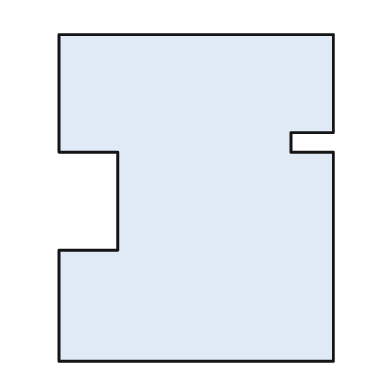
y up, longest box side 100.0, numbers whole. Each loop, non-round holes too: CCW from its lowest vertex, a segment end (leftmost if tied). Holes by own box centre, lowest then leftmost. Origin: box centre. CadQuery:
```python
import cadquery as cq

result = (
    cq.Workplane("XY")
    .moveTo(-42.0, -50.0)
    .lineTo(42.0, -50.0)
    .lineTo(42.0, 14.0)
    .lineTo(29.0, 14.0)
    .lineTo(29.0, 20.0)
    .lineTo(42.0, 20.0)
    .lineTo(42.0, 50.0)
    .lineTo(-42.0, 50.0)
    .lineTo(-42.0, 14.0)
    .lineTo(-24.0, 14.0)
    .lineTo(-24.0, -16.0)
    .lineTo(-42.0, -16.0)
    .close()
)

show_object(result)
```